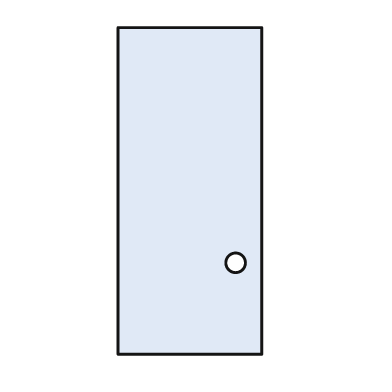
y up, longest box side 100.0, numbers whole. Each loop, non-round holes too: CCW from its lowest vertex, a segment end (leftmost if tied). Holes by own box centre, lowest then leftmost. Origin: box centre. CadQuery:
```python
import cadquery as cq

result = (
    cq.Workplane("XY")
    .moveTo(-22.0, -50.0)
    .lineTo(22.0, -50.0)
    .lineTo(22.0, 50.0)
    .lineTo(-22.0, 50.0)
    .close()
    .moveTo(14.0, -22.0)
    .circle(3.0)
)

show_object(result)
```